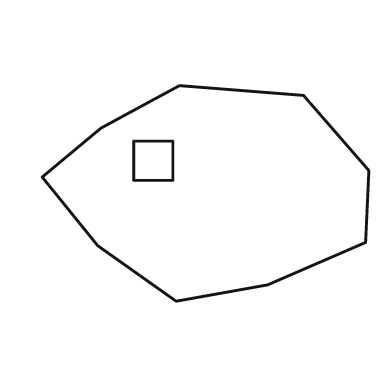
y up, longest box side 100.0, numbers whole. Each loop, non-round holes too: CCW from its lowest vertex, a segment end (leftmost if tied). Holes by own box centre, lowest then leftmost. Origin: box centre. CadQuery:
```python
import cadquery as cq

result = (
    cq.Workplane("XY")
    .moveTo(-9.0, -33.0)
    .lineTo(19.0, -28.0)
    .lineTo(49.0, -15.0)
    .lineTo(50.0, 7.0)
    .lineTo(30.0, 30.0)
    .lineTo(-8.0, 33.0)
    .lineTo(-32.0, 20.0)
    .lineTo(-50.0, 5.0)
    .lineTo(-33.0, -16.0)
    .close()
    .moveTo(-22.0, 4.0)
    .lineTo(-10.0, 4.0)
    .lineTo(-10.0, 16.0)
    .lineTo(-22.0, 16.0)
    .close()
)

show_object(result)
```